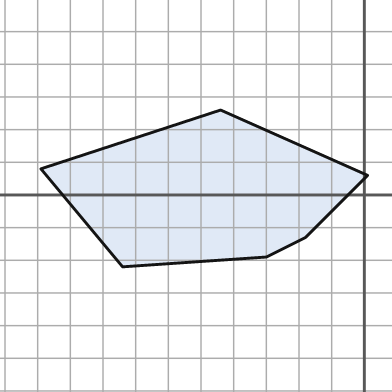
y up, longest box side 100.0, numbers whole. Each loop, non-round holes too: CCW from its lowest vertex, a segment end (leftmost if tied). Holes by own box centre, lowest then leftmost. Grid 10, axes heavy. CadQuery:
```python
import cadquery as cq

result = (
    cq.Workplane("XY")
    .moveTo(-74.0, -22.0)
    .lineTo(-30.0, -19.0)
    .lineTo(-18.0, -13.0)
    .lineTo(1.0, 6.0)
    .lineTo(-44.0, 26.0)
    .lineTo(-99.0, 8.0)
    .close()
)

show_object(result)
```